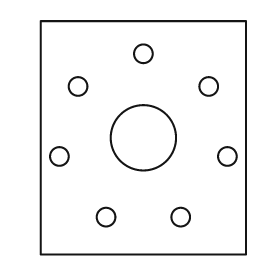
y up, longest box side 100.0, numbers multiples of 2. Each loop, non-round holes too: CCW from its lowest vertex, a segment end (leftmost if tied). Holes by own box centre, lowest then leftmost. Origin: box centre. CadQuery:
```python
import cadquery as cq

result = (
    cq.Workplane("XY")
    .moveTo(-44.0, -50.0)
    .lineTo(44.0, -50.0)
    .lineTo(44.0, 50.0)
    .lineTo(-44.0, 50.0)
    .close()
    .moveTo(-16.0, -34.0)
    .circle(4.0)
    .moveTo(16.0, -34.0)
    .circle(4.0)
    .moveTo(-36.0, -8.0)
    .circle(4.0)
    .moveTo(36.0, -8.0)
    .circle(4.0)
    .moveTo(0.0, 0.0)
    .circle(14.0)
    .moveTo(-28.0, 22.0)
    .circle(4.0)
    .moveTo(28.0, 22.0)
    .circle(4.0)
    .moveTo(0.0, 36.0)
    .circle(4.0)
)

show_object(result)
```